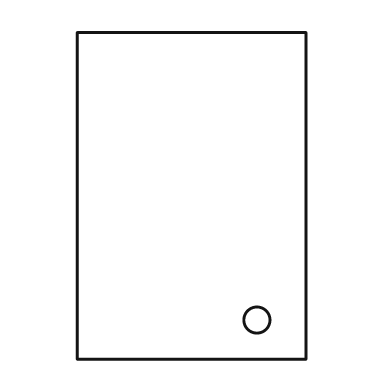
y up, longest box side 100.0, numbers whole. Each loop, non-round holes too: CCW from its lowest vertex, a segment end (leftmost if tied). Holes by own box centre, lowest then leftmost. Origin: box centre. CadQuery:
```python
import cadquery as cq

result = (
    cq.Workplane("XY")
    .moveTo(-35.0, -50.0)
    .lineTo(35.0, -50.0)
    .lineTo(35.0, 50.0)
    .lineTo(-35.0, 50.0)
    .close()
    .moveTo(20.0, -38.0)
    .circle(4.0)
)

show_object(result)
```